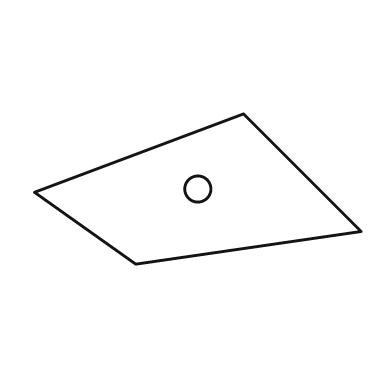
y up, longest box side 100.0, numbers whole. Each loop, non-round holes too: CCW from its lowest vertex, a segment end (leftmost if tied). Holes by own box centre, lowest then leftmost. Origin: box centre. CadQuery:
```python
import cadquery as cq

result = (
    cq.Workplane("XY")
    .moveTo(-19.0, -23.0)
    .lineTo(50.0, -13.0)
    .lineTo(14.0, 23.0)
    .lineTo(-50.0, -1.0)
    .close()
    .moveTo(0.0, 0.0)
    .circle(4.0)
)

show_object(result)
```